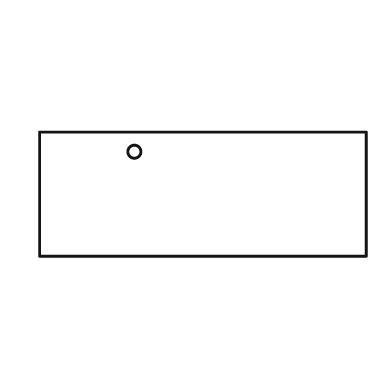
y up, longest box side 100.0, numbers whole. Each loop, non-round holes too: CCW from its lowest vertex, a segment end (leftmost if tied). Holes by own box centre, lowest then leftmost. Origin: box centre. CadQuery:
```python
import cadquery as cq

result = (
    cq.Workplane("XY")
    .moveTo(-50.0, -19.0)
    .lineTo(50.0, -19.0)
    .lineTo(50.0, 19.0)
    .lineTo(-50.0, 19.0)
    .close()
    .moveTo(-21.0, 13.0)
    .circle(2.0)
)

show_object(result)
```